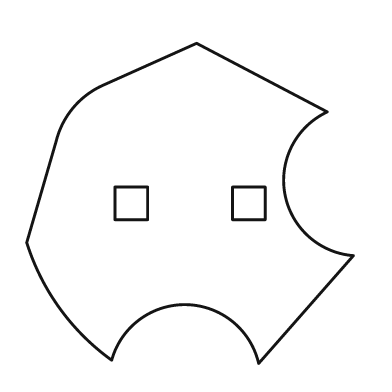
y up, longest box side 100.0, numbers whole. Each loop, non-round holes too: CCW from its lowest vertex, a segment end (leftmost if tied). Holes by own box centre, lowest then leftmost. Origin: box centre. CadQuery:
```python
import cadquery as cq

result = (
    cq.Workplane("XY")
    .moveTo(21.0, -49.0)
    .lineTo(50.0, -16.0)
    .threePointArc((29.0, 3.0), (42.0, 28.0))
    .lineTo(2.0, 49.0)
    .lineTo(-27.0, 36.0)
    .threePointArc((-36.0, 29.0), (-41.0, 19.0))
    .lineTo(-50.0, -12.0)
    .threePointArc((-40.0, -32.0), (-24.0, -48.0))
    .threePointArc((-1.0, -31.0), (21.0, -49.0))
    .close()
    .moveTo(-23.0, -5.0)
    .lineTo(-13.0, -5.0)
    .lineTo(-13.0, 5.0)
    .lineTo(-23.0, 5.0)
    .close()
    .moveTo(13.0, -5.0)
    .lineTo(23.0, -5.0)
    .lineTo(23.0, 5.0)
    .lineTo(13.0, 5.0)
    .close()
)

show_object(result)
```